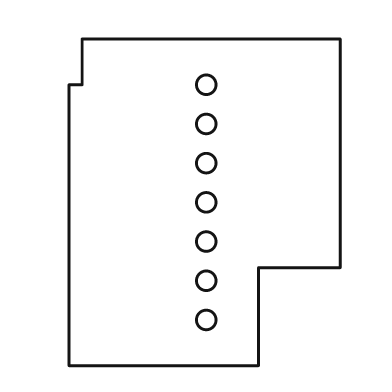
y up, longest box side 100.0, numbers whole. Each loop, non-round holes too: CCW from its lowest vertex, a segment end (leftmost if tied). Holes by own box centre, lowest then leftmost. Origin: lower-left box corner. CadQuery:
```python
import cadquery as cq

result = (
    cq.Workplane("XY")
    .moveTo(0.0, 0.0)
    .lineTo(58.0, 0.0)
    .lineTo(58.0, 30.0)
    .lineTo(83.0, 30.0)
    .lineTo(83.0, 100.0)
    .lineTo(4.0, 100.0)
    .lineTo(4.0, 86.0)
    .lineTo(0.0, 86.0)
    .close()
    .moveTo(42.0, 14.0)
    .circle(3.0)
    .moveTo(42.0, 26.0)
    .circle(3.0)
    .moveTo(42.0, 38.0)
    .circle(3.0)
    .moveTo(42.0, 50.0)
    .circle(3.0)
    .moveTo(42.0, 62.0)
    .circle(3.0)
    .moveTo(42.0, 74.0)
    .circle(3.0)
    .moveTo(42.0, 86.0)
    .circle(3.0)
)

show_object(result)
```